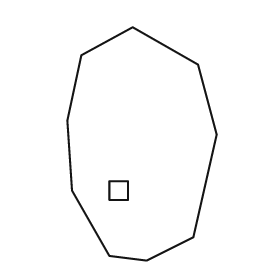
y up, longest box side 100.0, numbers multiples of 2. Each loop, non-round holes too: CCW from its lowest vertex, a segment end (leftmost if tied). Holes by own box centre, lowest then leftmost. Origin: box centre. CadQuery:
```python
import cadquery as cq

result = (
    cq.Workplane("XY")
    .moveTo(2.0, -50.0)
    .lineTo(22.0, -40.0)
    .lineTo(32.0, 4.0)
    .lineTo(24.0, 34.0)
    .lineTo(-4.0, 50.0)
    .lineTo(-26.0, 38.0)
    .lineTo(-32.0, 10.0)
    .lineTo(-30.0, -20.0)
    .lineTo(-14.0, -48.0)
    .close()
    .moveTo(-14.0, -24.0)
    .lineTo(-6.0, -24.0)
    .lineTo(-6.0, -16.0)
    .lineTo(-14.0, -16.0)
    .close()
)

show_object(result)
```